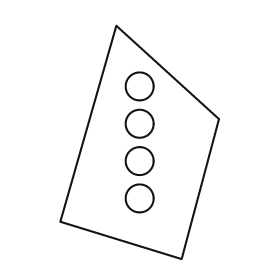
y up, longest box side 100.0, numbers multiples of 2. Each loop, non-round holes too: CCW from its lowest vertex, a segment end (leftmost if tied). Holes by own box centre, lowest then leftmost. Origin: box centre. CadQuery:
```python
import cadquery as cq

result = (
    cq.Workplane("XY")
    .moveTo(18.0, -50.0)
    .lineTo(34.0, 10.0)
    .lineTo(-10.0, 50.0)
    .lineTo(-34.0, -34.0)
    .close()
    .moveTo(0.0, -24.0)
    .circle(6.0)
    .moveTo(0.0, -8.0)
    .circle(6.0)
    .moveTo(0.0, 8.0)
    .circle(6.0)
    .moveTo(0.0, 24.0)
    .circle(6.0)
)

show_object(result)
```